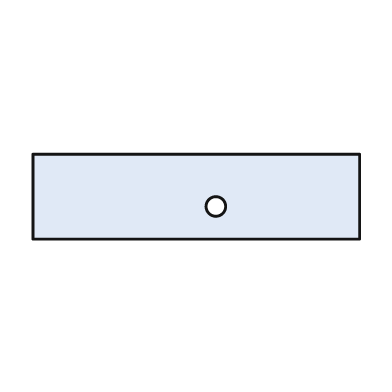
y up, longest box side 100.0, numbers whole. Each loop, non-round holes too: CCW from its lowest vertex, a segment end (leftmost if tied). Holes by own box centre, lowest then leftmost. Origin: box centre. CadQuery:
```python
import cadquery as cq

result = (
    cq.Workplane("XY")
    .moveTo(-50.0, -13.0)
    .lineTo(50.0, -13.0)
    .lineTo(50.0, 13.0)
    .lineTo(-50.0, 13.0)
    .close()
    .moveTo(6.0, -3.0)
    .circle(3.0)
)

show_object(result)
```